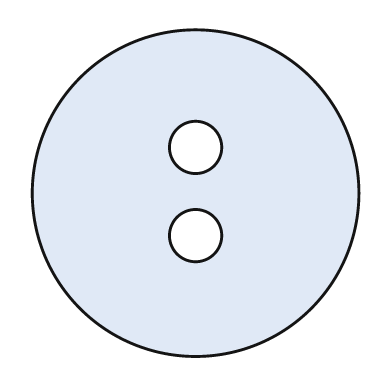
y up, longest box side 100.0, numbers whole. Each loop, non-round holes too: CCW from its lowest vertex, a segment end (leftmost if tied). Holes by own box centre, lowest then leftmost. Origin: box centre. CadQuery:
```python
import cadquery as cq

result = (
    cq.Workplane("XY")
    .moveTo(0.0, 0.0)
    .circle(50.0)
    .moveTo(0.0, -13.0)
    .circle(8.0)
    .moveTo(0.0, 14.0)
    .circle(8.0)
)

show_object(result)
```